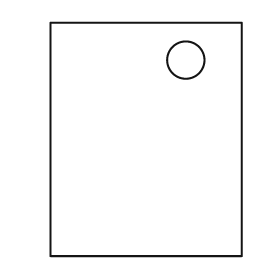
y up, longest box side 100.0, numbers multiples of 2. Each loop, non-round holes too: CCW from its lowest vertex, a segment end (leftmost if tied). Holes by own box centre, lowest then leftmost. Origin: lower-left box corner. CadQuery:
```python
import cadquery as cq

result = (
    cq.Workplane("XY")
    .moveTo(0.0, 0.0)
    .lineTo(82.0, 0.0)
    .lineTo(82.0, 100.0)
    .lineTo(0.0, 100.0)
    .close()
    .moveTo(58.0, 84.0)
    .circle(8.0)
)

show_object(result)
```